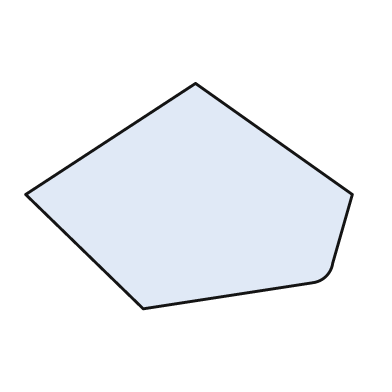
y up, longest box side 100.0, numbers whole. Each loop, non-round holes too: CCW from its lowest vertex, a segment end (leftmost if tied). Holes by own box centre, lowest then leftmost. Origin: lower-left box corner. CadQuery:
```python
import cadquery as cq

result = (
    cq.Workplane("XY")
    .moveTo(36.0, 0.0)
    .lineTo(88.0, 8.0)
    .threePointArc((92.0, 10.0), (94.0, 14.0))
    .lineTo(100.0, 35.0)
    .lineTo(52.0, 69.0)
    .lineTo(0.0, 35.0)
    .close()
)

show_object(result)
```